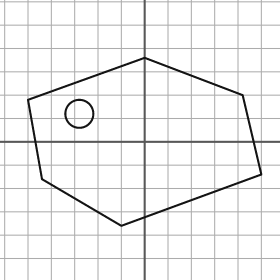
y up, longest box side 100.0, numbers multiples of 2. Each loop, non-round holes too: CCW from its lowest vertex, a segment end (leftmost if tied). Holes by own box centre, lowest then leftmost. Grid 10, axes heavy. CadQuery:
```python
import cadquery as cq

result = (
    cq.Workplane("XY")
    .moveTo(-10.0, -36.0)
    .lineTo(50.0, -14.0)
    .lineTo(42.0, 20.0)
    .lineTo(0.0, 36.0)
    .lineTo(-50.0, 18.0)
    .lineTo(-44.0, -16.0)
    .close()
    .moveTo(-28.0, 12.0)
    .circle(6.0)
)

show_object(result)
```